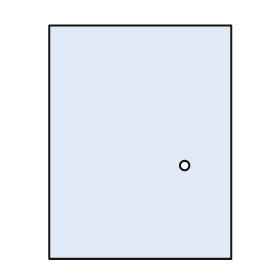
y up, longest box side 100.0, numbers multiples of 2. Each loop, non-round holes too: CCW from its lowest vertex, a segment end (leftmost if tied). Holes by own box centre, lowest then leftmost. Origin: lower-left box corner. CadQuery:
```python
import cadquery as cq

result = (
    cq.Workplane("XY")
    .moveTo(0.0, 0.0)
    .lineTo(78.0, 0.0)
    .lineTo(78.0, 100.0)
    .lineTo(0.0, 100.0)
    .close()
    .moveTo(58.0, 40.0)
    .circle(2.0)
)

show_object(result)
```